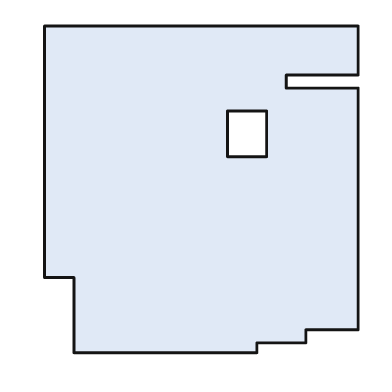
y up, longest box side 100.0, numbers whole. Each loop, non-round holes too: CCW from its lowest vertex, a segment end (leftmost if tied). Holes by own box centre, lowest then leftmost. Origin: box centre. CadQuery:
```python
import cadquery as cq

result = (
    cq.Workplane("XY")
    .moveTo(-39.0, -50.0)
    .lineTo(17.0, -50.0)
    .lineTo(17.0, -47.0)
    .lineTo(32.0, -47.0)
    .lineTo(32.0, -43.0)
    .lineTo(48.0, -43.0)
    .lineTo(48.0, 31.0)
    .lineTo(26.0, 31.0)
    .lineTo(26.0, 35.0)
    .lineTo(48.0, 35.0)
    .lineTo(48.0, 50.0)
    .lineTo(-48.0, 50.0)
    .lineTo(-48.0, -27.0)
    .lineTo(-39.0, -27.0)
    .close()
    .moveTo(8.0, 10.0)
    .lineTo(20.0, 10.0)
    .lineTo(20.0, 24.0)
    .lineTo(8.0, 24.0)
    .close()
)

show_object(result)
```